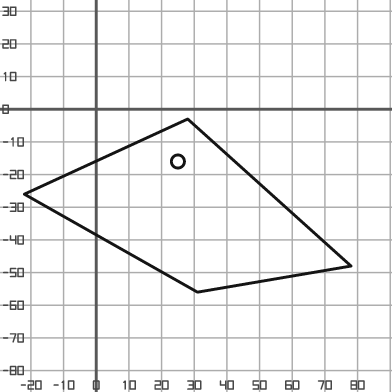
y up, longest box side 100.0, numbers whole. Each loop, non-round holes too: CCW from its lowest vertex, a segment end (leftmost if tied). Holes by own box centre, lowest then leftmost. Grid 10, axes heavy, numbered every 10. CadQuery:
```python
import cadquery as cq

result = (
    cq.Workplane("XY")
    .moveTo(31.0, -56.0)
    .lineTo(78.0, -48.0)
    .lineTo(28.0, -3.0)
    .lineTo(-22.0, -26.0)
    .close()
    .moveTo(25.0, -16.0)
    .circle(2.0)
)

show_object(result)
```